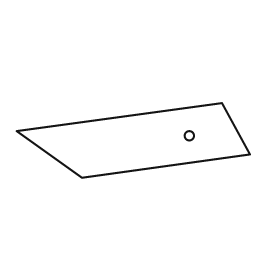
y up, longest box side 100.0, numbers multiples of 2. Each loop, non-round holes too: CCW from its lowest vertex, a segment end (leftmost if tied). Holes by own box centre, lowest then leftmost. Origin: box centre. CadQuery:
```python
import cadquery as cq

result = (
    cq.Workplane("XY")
    .moveTo(-22.0, -16.0)
    .lineTo(50.0, -6.0)
    .lineTo(38.0, 16.0)
    .lineTo(-50.0, 4.0)
    .close()
    .moveTo(24.0, 2.0)
    .circle(2.0)
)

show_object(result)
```